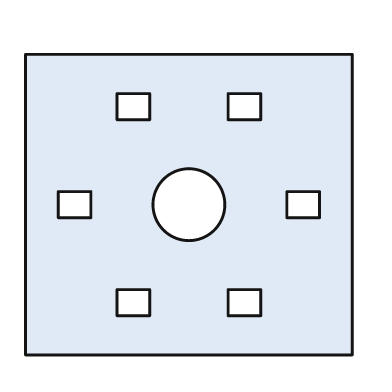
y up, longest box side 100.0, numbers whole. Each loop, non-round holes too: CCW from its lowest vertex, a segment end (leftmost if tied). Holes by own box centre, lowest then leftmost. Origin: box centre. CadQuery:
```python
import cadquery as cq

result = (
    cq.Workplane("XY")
    .moveTo(-50.0, -46.0)
    .lineTo(50.0, -46.0)
    .lineTo(50.0, 46.0)
    .lineTo(-50.0, 46.0)
    .close()
    .moveTo(-22.0, -34.0)
    .lineTo(-12.0, -34.0)
    .lineTo(-12.0, -26.0)
    .lineTo(-22.0, -26.0)
    .close()
    .moveTo(12.0, -34.0)
    .lineTo(22.0, -34.0)
    .lineTo(22.0, -26.0)
    .lineTo(12.0, -26.0)
    .close()
    .moveTo(-40.0, -4.0)
    .lineTo(-30.0, -4.0)
    .lineTo(-30.0, 4.0)
    .lineTo(-40.0, 4.0)
    .close()
    .moveTo(0.0, 0.0)
    .circle(11.0)
    .moveTo(30.0, -4.0)
    .lineTo(40.0, -4.0)
    .lineTo(40.0, 4.0)
    .lineTo(30.0, 4.0)
    .close()
    .moveTo(-22.0, 26.0)
    .lineTo(-12.0, 26.0)
    .lineTo(-12.0, 34.0)
    .lineTo(-22.0, 34.0)
    .close()
    .moveTo(12.0, 26.0)
    .lineTo(22.0, 26.0)
    .lineTo(22.0, 34.0)
    .lineTo(12.0, 34.0)
    .close()
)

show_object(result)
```